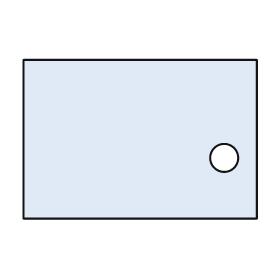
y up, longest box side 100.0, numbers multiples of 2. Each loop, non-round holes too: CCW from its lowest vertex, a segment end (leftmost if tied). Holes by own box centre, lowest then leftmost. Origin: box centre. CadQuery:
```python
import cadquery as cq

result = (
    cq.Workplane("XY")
    .moveTo(-50.0, -34.0)
    .lineTo(50.0, -34.0)
    .lineTo(50.0, 34.0)
    .lineTo(-50.0, 34.0)
    .close()
    .moveTo(36.0, -8.0)
    .circle(6.0)
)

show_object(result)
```